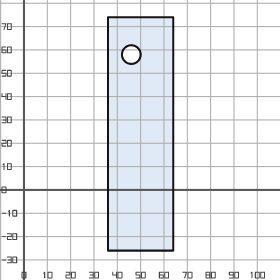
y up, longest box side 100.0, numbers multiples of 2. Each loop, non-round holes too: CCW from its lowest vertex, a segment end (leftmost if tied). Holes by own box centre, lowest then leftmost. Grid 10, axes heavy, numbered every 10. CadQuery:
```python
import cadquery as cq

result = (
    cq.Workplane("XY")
    .moveTo(36.0, -26.0)
    .lineTo(64.0, -26.0)
    .lineTo(64.0, 74.0)
    .lineTo(36.0, 74.0)
    .close()
    .moveTo(46.0, 58.0)
    .circle(4.0)
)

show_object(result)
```